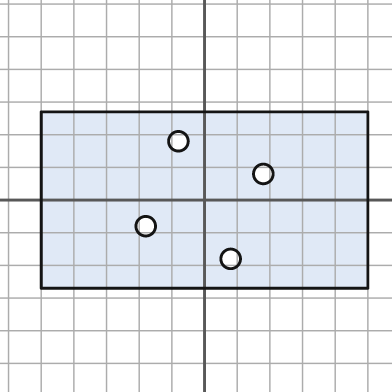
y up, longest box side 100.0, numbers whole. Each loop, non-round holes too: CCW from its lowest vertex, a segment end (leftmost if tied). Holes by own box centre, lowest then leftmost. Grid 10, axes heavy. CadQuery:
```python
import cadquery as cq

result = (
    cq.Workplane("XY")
    .moveTo(-50.0, -27.0)
    .lineTo(50.0, -27.0)
    .lineTo(50.0, 27.0)
    .lineTo(-50.0, 27.0)
    .close()
    .moveTo(8.0, -18.0)
    .circle(3.0)
    .moveTo(-18.0, -8.0)
    .circle(3.0)
    .moveTo(18.0, 8.0)
    .circle(3.0)
    .moveTo(-8.0, 18.0)
    .circle(3.0)
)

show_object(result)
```